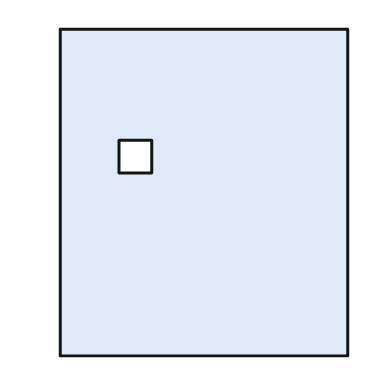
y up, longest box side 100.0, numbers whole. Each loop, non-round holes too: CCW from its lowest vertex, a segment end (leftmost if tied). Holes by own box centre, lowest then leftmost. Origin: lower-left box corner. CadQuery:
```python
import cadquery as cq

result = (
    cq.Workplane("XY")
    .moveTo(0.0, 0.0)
    .lineTo(88.0, 0.0)
    .lineTo(88.0, 100.0)
    .lineTo(0.0, 100.0)
    .close()
    .moveTo(18.0, 56.0)
    .lineTo(28.0, 56.0)
    .lineTo(28.0, 66.0)
    .lineTo(18.0, 66.0)
    .close()
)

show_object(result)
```